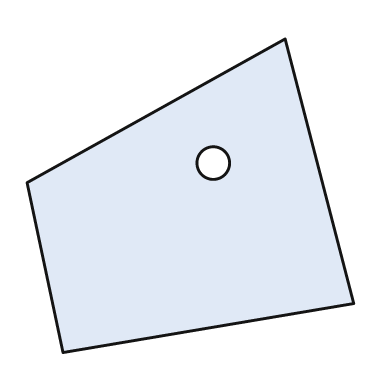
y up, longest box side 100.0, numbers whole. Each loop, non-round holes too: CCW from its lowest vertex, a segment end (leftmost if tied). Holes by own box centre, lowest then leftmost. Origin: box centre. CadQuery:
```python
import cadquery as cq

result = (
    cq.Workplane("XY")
    .moveTo(-39.0, -48.0)
    .lineTo(50.0, -33.0)
    .lineTo(29.0, 48.0)
    .lineTo(-50.0, 4.0)
    .close()
    .moveTo(7.0, 10.0)
    .circle(5.0)
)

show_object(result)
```